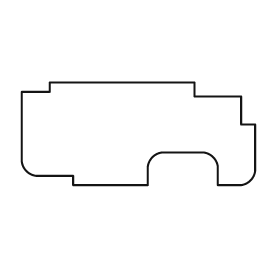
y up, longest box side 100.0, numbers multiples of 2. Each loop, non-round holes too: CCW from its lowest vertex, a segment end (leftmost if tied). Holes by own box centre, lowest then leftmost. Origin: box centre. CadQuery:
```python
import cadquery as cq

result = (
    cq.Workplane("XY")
    .moveTo(-28.0, -22.0)
    .lineTo(4.0, -22.0)
    .lineTo(4.0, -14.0)
    .threePointArc((6.0, -10.0), (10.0, -8.0))
    .lineTo(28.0, -8.0)
    .threePointArc((32.0, -10.0), (34.0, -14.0))
    .lineTo(34.0, -22.0)
    .lineTo(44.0, -22.0)
    .threePointArc((48.0, -20.0), (50.0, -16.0))
    .lineTo(50.0, 4.0)
    .lineTo(44.0, 4.0)
    .lineTo(44.0, 16.0)
    .lineTo(24.0, 16.0)
    .lineTo(24.0, 22.0)
    .lineTo(-38.0, 22.0)
    .lineTo(-38.0, 18.0)
    .lineTo(-50.0, 18.0)
    .lineTo(-50.0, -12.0)
    .threePointArc((-48.0, -16.0), (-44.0, -18.0))
    .lineTo(-28.0, -18.0)
    .close()
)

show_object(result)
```